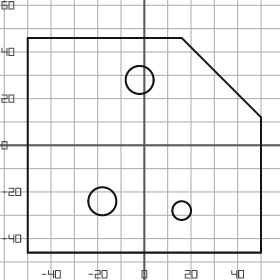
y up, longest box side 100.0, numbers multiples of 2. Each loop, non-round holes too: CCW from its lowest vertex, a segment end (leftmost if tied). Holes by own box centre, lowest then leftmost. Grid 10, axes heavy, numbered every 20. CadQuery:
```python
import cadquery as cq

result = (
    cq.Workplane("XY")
    .moveTo(-50.0, -46.0)
    .lineTo(50.0, -46.0)
    .lineTo(50.0, 12.0)
    .lineTo(16.0, 46.0)
    .lineTo(-50.0, 46.0)
    .close()
    .moveTo(16.0, -28.0)
    .circle(4.0)
    .moveTo(-18.0, -24.0)
    .circle(6.0)
    .moveTo(-2.0, 28.0)
    .circle(6.0)
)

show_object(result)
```